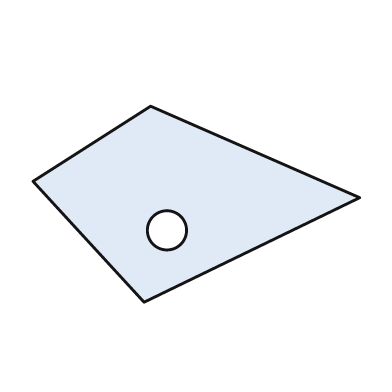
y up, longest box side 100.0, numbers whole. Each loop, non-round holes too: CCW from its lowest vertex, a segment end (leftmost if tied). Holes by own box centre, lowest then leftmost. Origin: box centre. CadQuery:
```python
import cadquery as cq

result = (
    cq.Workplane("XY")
    .moveTo(-16.0, -30.0)
    .lineTo(50.0, 2.0)
    .lineTo(-14.0, 30.0)
    .lineTo(-50.0, 7.0)
    .close()
    .moveTo(-9.0, -8.0)
    .circle(6.0)
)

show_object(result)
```